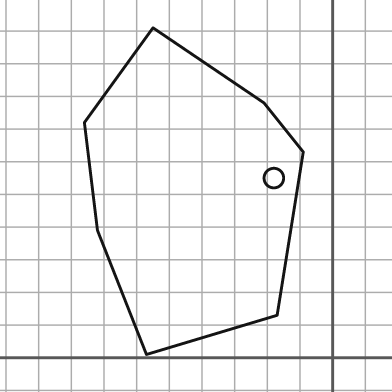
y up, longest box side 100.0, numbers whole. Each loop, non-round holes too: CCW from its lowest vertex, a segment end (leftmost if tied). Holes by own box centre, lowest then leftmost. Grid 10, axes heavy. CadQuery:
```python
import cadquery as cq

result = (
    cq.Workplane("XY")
    .moveTo(-57.0, 1.0)
    .lineTo(-17.0, 13.0)
    .lineTo(-9.0, 63.0)
    .lineTo(-21.0, 78.0)
    .lineTo(-55.0, 101.0)
    .lineTo(-76.0, 72.0)
    .lineTo(-72.0, 39.0)
    .close()
    .moveTo(-18.0, 55.0)
    .circle(3.0)
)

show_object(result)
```